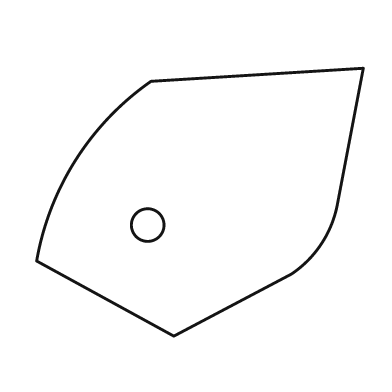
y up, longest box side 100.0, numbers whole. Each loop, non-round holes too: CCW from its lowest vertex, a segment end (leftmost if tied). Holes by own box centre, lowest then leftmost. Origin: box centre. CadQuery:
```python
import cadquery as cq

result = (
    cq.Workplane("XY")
    .moveTo(-8.0, -41.0)
    .lineTo(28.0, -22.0)
    .threePointArc((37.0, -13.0), (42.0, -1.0))
    .lineTo(50.0, 41.0)
    .lineTo(-15.0, 37.0)
    .threePointArc((-38.0, 13.0), (-50.0, -18.0))
    .close()
    .moveTo(-16.0, -7.0)
    .circle(5.0)
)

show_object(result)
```